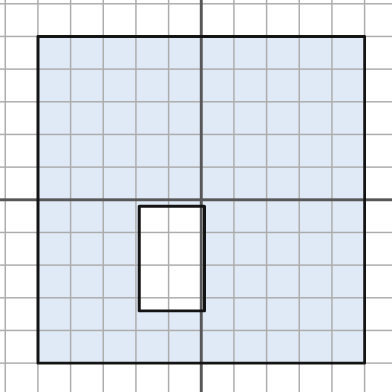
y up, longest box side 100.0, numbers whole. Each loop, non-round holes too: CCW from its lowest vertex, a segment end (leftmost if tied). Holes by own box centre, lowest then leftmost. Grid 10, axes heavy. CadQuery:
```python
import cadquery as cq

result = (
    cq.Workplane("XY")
    .moveTo(-50.0, -50.0)
    .lineTo(50.0, -50.0)
    .lineTo(50.0, 50.0)
    .lineTo(-50.0, 50.0)
    .close()
    .moveTo(-19.0, -34.0)
    .lineTo(1.0, -34.0)
    .lineTo(1.0, -2.0)
    .lineTo(-19.0, -2.0)
    .close()
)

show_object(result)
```